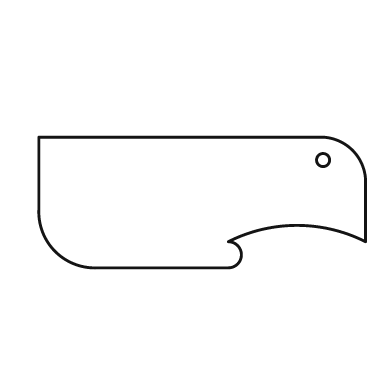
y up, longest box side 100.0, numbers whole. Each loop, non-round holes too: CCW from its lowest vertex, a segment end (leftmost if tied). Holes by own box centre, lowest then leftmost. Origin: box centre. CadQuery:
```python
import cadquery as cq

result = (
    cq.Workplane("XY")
    .moveTo(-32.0, -20.0)
    .lineTo(8.0, -20.0)
    .threePointArc((12.0, -16.0), (8.0, -12.0))
    .threePointArc((29.0, -7.0), (50.0, -12.0))
    .lineTo(50.0, 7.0)
    .threePointArc((46.0, 16.0), (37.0, 20.0))
    .lineTo(-50.0, 20.0)
    .lineTo(-50.0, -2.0)
    .threePointArc((-45.0, -15.0), (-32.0, -20.0))
    .close()
    .moveTo(37.0, 13.0)
    .circle(2.0)
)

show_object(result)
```